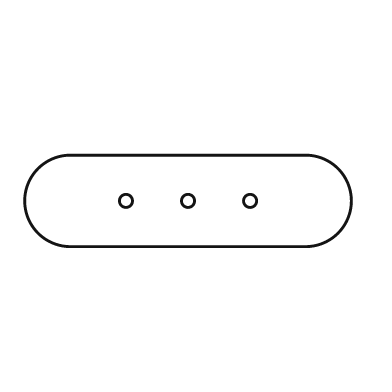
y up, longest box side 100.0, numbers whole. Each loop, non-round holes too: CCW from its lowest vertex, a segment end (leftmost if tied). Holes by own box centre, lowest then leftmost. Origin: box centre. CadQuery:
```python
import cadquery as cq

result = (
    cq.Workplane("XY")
    .moveTo(-36.0, -14.0)
    .lineTo(36.0, -14.0)
    .threePointArc((50.0, 0.0), (36.0, 14.0))
    .lineTo(-36.0, 14.0)
    .threePointArc((-50.0, 0.0), (-36.0, -14.0))
    .close()
    .moveTo(-19.0, 0.0)
    .circle(2.0)
    .moveTo(0.0, 0.0)
    .circle(2.0)
    .moveTo(19.0, 0.0)
    .circle(2.0)
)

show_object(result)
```